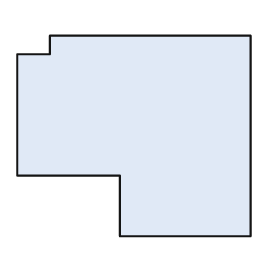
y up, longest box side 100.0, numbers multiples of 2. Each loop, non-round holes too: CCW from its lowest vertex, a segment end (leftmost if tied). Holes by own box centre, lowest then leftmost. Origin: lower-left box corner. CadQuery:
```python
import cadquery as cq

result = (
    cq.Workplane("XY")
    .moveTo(44.0, 0.0)
    .lineTo(100.0, 0.0)
    .lineTo(100.0, 86.0)
    .lineTo(14.0, 86.0)
    .lineTo(14.0, 78.0)
    .lineTo(0.0, 78.0)
    .lineTo(0.0, 26.0)
    .lineTo(44.0, 26.0)
    .close()
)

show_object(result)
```